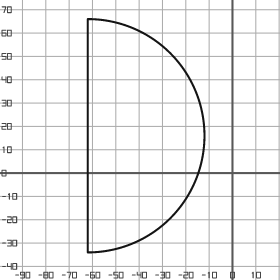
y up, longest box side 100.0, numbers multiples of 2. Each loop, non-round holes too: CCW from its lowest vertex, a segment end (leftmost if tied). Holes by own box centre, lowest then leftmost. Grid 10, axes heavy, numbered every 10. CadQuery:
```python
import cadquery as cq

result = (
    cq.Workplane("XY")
    .moveTo(-62.0, -34.0)
    .threePointArc((-12.0, 16.0), (-62.0, 66.0))
    .close()
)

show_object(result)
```